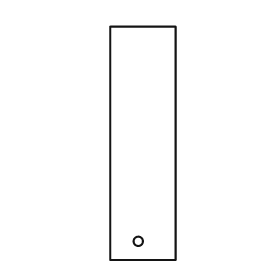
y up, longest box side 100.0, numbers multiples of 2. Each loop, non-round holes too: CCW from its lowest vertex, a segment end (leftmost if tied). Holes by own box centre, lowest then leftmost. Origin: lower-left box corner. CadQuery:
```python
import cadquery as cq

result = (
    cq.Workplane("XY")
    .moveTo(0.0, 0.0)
    .lineTo(28.0, 0.0)
    .lineTo(28.0, 100.0)
    .lineTo(0.0, 100.0)
    .close()
    .moveTo(12.0, 8.0)
    .circle(2.0)
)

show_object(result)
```